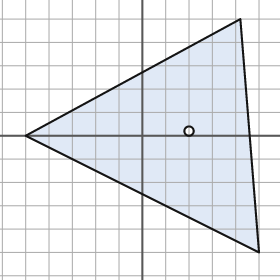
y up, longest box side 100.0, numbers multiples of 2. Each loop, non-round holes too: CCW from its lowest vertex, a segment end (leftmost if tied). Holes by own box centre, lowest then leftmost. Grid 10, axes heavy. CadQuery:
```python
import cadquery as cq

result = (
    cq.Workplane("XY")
    .moveTo(50.0, -50.0)
    .lineTo(42.0, 50.0)
    .lineTo(-50.0, 0.0)
    .close()
    .moveTo(20.0, 2.0)
    .circle(2.0)
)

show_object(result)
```